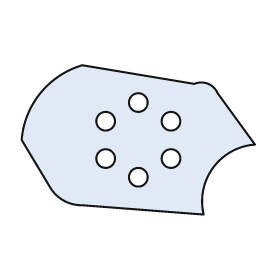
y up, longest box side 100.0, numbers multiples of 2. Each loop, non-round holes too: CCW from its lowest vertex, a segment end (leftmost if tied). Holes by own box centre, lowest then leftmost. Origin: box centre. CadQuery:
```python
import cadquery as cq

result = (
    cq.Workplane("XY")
    .moveTo(28.0, -32.0)
    .threePointArc((32.0, -12.0), (50.0, -2.0))
    .lineTo(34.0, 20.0)
    .threePointArc((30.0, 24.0), (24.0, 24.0))
    .lineTo(-24.0, 32.0)
    .threePointArc((-42.0, 20.0), (-50.0, 0.0))
    .lineTo(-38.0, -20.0)
    .threePointArc((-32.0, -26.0), (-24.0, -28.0))
    .close()
    .moveTo(0.0, -16.0)
    .circle(4.0)
    .moveTo(-14.0, -8.0)
    .circle(4.0)
    .moveTo(14.0, -8.0)
    .circle(4.0)
    .moveTo(-14.0, 8.0)
    .circle(4.0)
    .moveTo(14.0, 8.0)
    .circle(4.0)
    .moveTo(0.0, 16.0)
    .circle(4.0)
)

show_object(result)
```